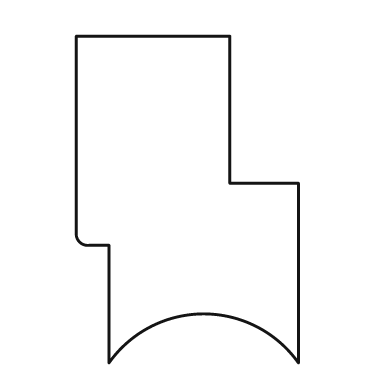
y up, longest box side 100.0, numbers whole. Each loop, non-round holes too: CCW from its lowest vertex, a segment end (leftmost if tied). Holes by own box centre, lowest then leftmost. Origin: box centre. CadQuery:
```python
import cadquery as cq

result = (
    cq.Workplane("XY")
    .moveTo(-24.0, -50.0)
    .threePointArc((5.0, -35.0), (34.0, -50.0))
    .lineTo(34.0, 5.0)
    .lineTo(13.0, 5.0)
    .lineTo(13.0, 50.0)
    .lineTo(-34.0, 50.0)
    .lineTo(-34.0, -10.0)
    .threePointArc((-33.0, -13.0), (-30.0, -14.0))
    .lineTo(-24.0, -14.0)
    .close()
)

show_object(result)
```